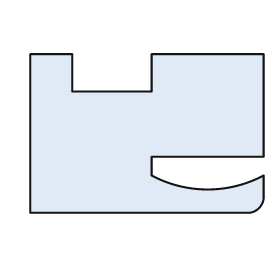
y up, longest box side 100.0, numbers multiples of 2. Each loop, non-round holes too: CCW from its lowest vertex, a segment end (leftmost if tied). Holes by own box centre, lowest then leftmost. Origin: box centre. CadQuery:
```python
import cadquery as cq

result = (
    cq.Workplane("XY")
    .moveTo(-50.0, -34.0)
    .lineTo(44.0, -34.0)
    .threePointArc((48.0, -32.0), (50.0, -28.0))
    .lineTo(50.0, -18.0)
    .threePointArc((26.0, -24.0), (2.0, -18.0))
    .lineTo(2.0, -10.0)
    .lineTo(50.0, -10.0)
    .lineTo(50.0, 34.0)
    .lineTo(2.0, 34.0)
    .lineTo(2.0, 18.0)
    .lineTo(-32.0, 18.0)
    .lineTo(-32.0, 34.0)
    .lineTo(-50.0, 34.0)
    .close()
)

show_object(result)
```